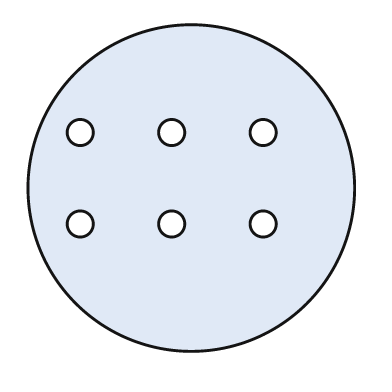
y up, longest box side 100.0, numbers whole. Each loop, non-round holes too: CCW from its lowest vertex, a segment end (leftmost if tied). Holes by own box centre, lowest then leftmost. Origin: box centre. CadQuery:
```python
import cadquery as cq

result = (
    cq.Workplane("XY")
    .moveTo(0.0, 0.0)
    .circle(50.0)
    .moveTo(-34.0, -11.0)
    .circle(4.0)
    .moveTo(-6.0, -11.0)
    .circle(4.0)
    .moveTo(22.0, -11.0)
    .circle(4.0)
    .moveTo(-34.0, 17.0)
    .circle(4.0)
    .moveTo(-6.0, 17.0)
    .circle(4.0)
    .moveTo(22.0, 17.0)
    .circle(4.0)
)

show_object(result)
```